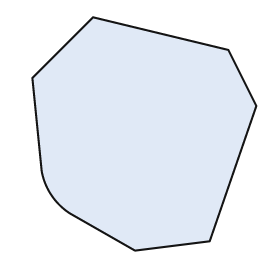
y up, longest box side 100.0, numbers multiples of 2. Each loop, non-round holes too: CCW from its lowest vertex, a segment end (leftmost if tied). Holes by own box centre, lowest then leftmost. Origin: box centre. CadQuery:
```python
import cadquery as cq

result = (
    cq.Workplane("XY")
    .moveTo(-4.0, -50.0)
    .lineTo(28.0, -46.0)
    .lineTo(48.0, 12.0)
    .lineTo(36.0, 36.0)
    .lineTo(-22.0, 50.0)
    .lineTo(-48.0, 24.0)
    .lineTo(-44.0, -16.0)
    .threePointArc((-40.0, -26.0), (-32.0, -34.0))
    .close()
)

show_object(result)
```